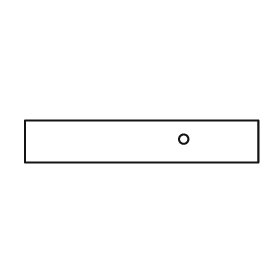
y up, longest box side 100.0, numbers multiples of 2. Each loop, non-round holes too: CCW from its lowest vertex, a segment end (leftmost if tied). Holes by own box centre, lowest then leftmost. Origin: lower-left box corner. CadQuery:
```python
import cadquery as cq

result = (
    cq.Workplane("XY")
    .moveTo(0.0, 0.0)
    .lineTo(100.0, 0.0)
    .lineTo(100.0, 18.0)
    .lineTo(0.0, 18.0)
    .close()
    .moveTo(68.0, 10.0)
    .circle(2.0)
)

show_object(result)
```